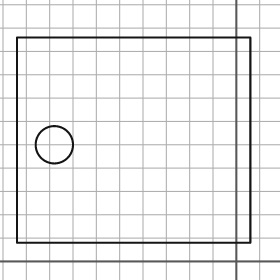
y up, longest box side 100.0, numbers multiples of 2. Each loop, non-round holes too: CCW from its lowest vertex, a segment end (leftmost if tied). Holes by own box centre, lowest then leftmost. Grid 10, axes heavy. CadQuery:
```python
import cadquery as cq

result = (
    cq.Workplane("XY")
    .moveTo(-94.0, 8.0)
    .lineTo(6.0, 8.0)
    .lineTo(6.0, 96.0)
    .lineTo(-94.0, 96.0)
    .close()
    .moveTo(-78.0, 50.0)
    .circle(8.0)
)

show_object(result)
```